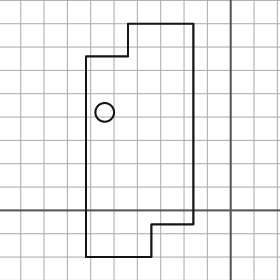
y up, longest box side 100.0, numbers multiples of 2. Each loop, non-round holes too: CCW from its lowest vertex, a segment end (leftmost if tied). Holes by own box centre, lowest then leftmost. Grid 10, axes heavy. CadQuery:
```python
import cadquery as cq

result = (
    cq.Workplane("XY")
    .moveTo(-62.0, -20.0)
    .lineTo(-34.0, -20.0)
    .lineTo(-34.0, -6.0)
    .lineTo(-16.0, -6.0)
    .lineTo(-16.0, 80.0)
    .lineTo(-44.0, 80.0)
    .lineTo(-44.0, 66.0)
    .lineTo(-62.0, 66.0)
    .close()
    .moveTo(-54.0, 42.0)
    .circle(4.0)
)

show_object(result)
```